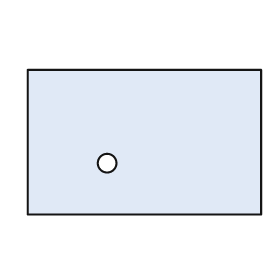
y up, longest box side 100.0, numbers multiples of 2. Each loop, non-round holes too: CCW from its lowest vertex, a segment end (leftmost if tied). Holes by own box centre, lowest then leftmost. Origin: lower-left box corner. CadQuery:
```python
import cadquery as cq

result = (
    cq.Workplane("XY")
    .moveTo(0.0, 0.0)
    .lineTo(100.0, 0.0)
    .lineTo(100.0, 62.0)
    .lineTo(0.0, 62.0)
    .close()
    .moveTo(34.0, 22.0)
    .circle(4.0)
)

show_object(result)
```